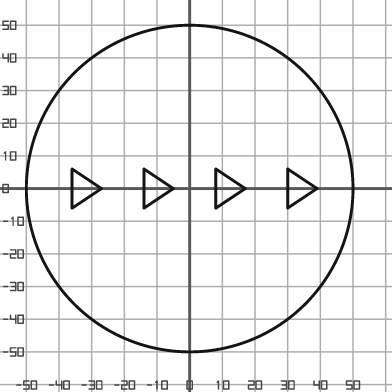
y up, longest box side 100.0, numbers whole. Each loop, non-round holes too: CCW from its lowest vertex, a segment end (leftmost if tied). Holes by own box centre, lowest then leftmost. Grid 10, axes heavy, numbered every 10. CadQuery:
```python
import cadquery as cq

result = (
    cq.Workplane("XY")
    .moveTo(0.0, 0.0)
    .circle(50.0)
    .moveTo(-36.0, -6.0)
    .lineTo(-27.0, 0.0)
    .lineTo(-36.0, 6.0)
    .close()
    .moveTo(-14.0, -6.0)
    .lineTo(-5.0, 0.0)
    .lineTo(-14.0, 6.0)
    .close()
    .moveTo(8.0, -6.0)
    .lineTo(17.0, 0.0)
    .lineTo(8.0, 6.0)
    .close()
    .moveTo(30.0, -6.0)
    .lineTo(39.0, 0.0)
    .lineTo(30.0, 6.0)
    .close()
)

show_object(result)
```